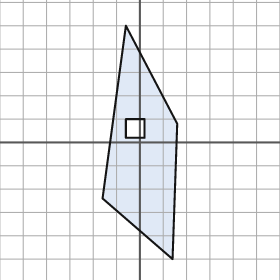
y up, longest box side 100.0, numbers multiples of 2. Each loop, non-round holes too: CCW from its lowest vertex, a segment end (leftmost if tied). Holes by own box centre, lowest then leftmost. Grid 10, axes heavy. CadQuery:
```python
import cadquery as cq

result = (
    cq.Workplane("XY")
    .moveTo(14.0, -50.0)
    .lineTo(16.0, 8.0)
    .lineTo(-6.0, 50.0)
    .lineTo(-16.0, -24.0)
    .close()
    .moveTo(-6.0, 2.0)
    .lineTo(2.0, 2.0)
    .lineTo(2.0, 10.0)
    .lineTo(-6.0, 10.0)
    .close()
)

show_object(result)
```